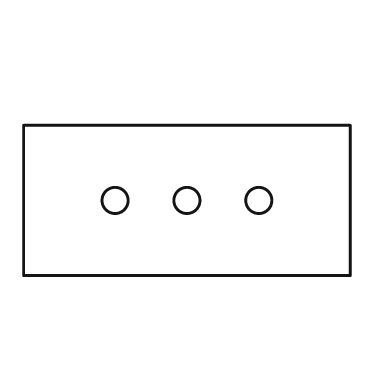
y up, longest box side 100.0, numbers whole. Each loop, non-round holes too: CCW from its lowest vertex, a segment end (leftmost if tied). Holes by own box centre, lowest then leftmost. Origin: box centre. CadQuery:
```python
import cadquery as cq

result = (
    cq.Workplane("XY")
    .moveTo(-50.0, -23.0)
    .lineTo(50.0, -23.0)
    .lineTo(50.0, 23.0)
    .lineTo(-50.0, 23.0)
    .close()
    .moveTo(-22.0, 0.0)
    .circle(4.0)
    .moveTo(0.0, 0.0)
    .circle(4.0)
    .moveTo(22.0, 0.0)
    .circle(4.0)
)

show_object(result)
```